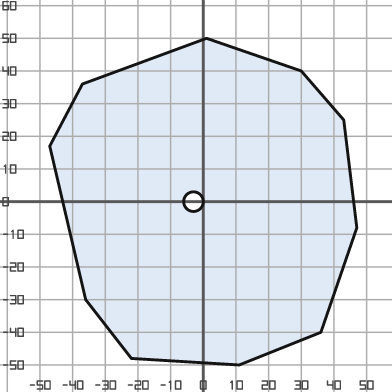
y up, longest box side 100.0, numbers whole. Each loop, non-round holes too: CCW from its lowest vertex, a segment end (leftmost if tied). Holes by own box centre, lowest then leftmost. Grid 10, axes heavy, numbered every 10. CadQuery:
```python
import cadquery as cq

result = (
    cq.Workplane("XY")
    .moveTo(11.0, -50.0)
    .lineTo(36.0, -40.0)
    .lineTo(47.0, -8.0)
    .lineTo(43.0, 25.0)
    .lineTo(30.0, 40.0)
    .lineTo(1.0, 50.0)
    .lineTo(-37.0, 36.0)
    .lineTo(-47.0, 17.0)
    .lineTo(-36.0, -30.0)
    .lineTo(-22.0, -48.0)
    .close()
    .moveTo(-3.0, 0.0)
    .circle(3.0)
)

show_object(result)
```